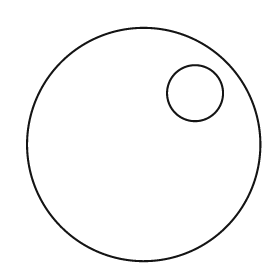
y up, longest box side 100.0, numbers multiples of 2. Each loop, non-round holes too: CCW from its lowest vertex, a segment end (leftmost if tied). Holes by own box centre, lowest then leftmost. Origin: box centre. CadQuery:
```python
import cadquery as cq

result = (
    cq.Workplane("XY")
    .moveTo(0.0, 0.0)
    .circle(50.0)
    .moveTo(22.0, 22.0)
    .circle(12.0)
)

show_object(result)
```